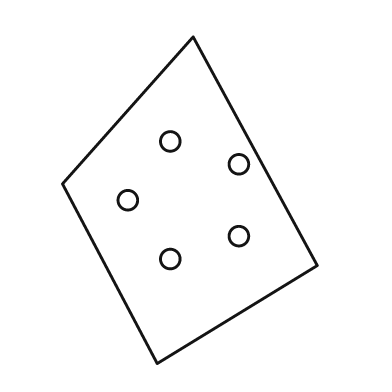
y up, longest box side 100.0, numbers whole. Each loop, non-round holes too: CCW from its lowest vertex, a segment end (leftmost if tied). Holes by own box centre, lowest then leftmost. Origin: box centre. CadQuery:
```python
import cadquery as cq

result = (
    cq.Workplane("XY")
    .moveTo(-10.0, -50.0)
    .lineTo(39.0, -20.0)
    .lineTo(1.0, 50.0)
    .lineTo(-39.0, 5.0)
    .close()
    .moveTo(-6.0, -18.0)
    .circle(3.0)
    .moveTo(15.0, -11.0)
    .circle(3.0)
    .moveTo(-19.0, 0.0)
    .circle(3.0)
    .moveTo(15.0, 11.0)
    .circle(3.0)
    .moveTo(-6.0, 18.0)
    .circle(3.0)
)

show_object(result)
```